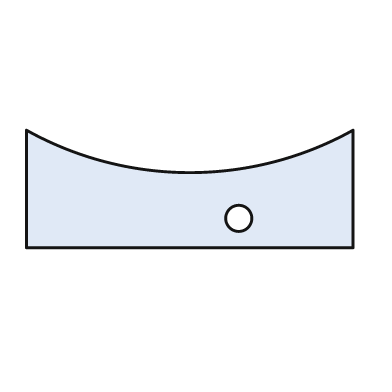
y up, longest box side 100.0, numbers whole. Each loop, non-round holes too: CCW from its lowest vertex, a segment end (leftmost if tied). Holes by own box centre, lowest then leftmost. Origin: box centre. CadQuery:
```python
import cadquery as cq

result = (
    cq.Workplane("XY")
    .moveTo(-50.0, -18.0)
    .lineTo(50.0, -18.0)
    .lineTo(50.0, 18.0)
    .threePointArc((0.0, 5.0), (-50.0, 18.0))
    .close()
    .moveTo(15.0, -9.0)
    .circle(4.0)
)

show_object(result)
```